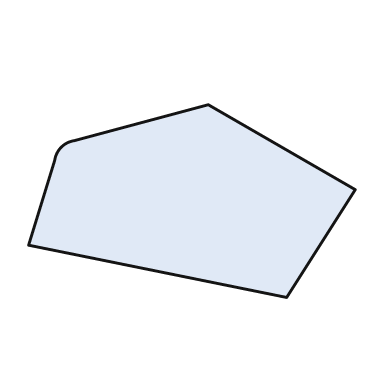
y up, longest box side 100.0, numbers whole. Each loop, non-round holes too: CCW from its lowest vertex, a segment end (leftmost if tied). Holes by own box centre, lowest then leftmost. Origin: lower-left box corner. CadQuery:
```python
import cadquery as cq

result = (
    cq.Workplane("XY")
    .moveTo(79.0, 0.0)
    .lineTo(100.0, 33.0)
    .lineTo(55.0, 59.0)
    .lineTo(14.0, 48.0)
    .threePointArc((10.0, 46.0), (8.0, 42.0))
    .lineTo(0.0, 16.0)
    .close()
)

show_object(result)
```